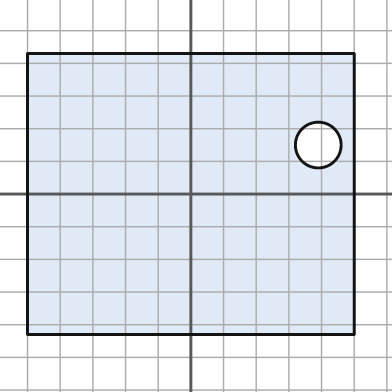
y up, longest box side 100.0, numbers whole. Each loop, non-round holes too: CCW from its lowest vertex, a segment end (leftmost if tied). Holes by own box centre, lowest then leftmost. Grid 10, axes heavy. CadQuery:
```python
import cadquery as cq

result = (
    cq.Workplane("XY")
    .moveTo(-50.0, -43.0)
    .lineTo(50.0, -43.0)
    .lineTo(50.0, 43.0)
    .lineTo(-50.0, 43.0)
    .close()
    .moveTo(39.0, 15.0)
    .circle(7.0)
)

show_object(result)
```